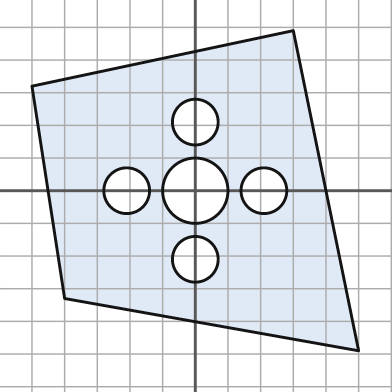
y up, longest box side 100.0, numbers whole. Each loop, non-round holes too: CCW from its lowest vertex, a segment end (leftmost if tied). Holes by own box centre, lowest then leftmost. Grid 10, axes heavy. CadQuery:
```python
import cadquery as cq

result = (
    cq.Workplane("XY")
    .moveTo(50.0, -49.0)
    .lineTo(30.0, 49.0)
    .lineTo(-50.0, 32.0)
    .lineTo(-40.0, -33.0)
    .close()
    .moveTo(0.0, -21.0)
    .circle(7.0)
    .moveTo(-21.0, 0.0)
    .circle(7.0)
    .moveTo(0.0, 0.0)
    .circle(10.0)
    .moveTo(21.0, 0.0)
    .circle(7.0)
    .moveTo(0.0, 21.0)
    .circle(7.0)
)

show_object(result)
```